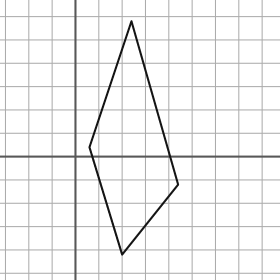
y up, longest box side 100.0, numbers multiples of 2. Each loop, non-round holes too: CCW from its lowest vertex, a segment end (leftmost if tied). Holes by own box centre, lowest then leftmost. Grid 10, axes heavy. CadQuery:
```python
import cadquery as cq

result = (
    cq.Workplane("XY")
    .moveTo(20.0, -42.0)
    .lineTo(44.0, -12.0)
    .lineTo(24.0, 58.0)
    .lineTo(6.0, 4.0)
    .close()
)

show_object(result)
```